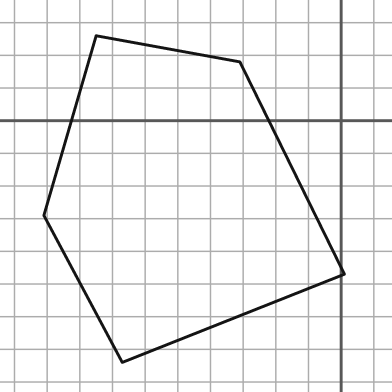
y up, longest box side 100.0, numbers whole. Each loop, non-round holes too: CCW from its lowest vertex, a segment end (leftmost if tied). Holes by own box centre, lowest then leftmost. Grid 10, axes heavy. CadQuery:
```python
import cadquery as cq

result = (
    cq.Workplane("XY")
    .moveTo(-67.0, -74.0)
    .lineTo(1.0, -47.0)
    .lineTo(-31.0, 18.0)
    .lineTo(-75.0, 26.0)
    .lineTo(-91.0, -29.0)
    .close()
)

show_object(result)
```